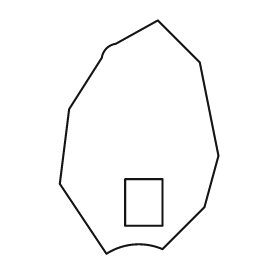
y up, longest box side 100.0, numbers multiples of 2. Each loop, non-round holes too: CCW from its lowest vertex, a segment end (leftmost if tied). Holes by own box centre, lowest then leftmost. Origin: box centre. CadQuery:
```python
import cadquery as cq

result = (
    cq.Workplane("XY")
    .moveTo(-14.0, -50.0)
    .threePointArc((-2.0, -46.0), (10.0, -48.0))
    .lineTo(28.0, -30.0)
    .lineTo(34.0, -8.0)
    .lineTo(26.0, 32.0)
    .lineTo(8.0, 50.0)
    .lineTo(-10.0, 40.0)
    .threePointArc((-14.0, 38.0), (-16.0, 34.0))
    .lineTo(-30.0, 12.0)
    .lineTo(-34.0, -20.0)
    .close()
    .moveTo(-6.0, -38.0)
    .lineTo(10.0, -38.0)
    .lineTo(10.0, -18.0)
    .lineTo(-6.0, -18.0)
    .close()
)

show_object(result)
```